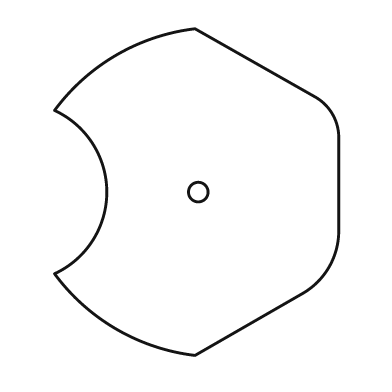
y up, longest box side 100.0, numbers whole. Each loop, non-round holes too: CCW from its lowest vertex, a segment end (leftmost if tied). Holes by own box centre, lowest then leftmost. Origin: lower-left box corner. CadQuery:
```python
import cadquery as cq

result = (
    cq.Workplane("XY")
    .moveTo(43.0, 0.0)
    .lineTo(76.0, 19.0)
    .threePointArc((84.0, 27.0), (87.0, 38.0))
    .lineTo(87.0, 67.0)
    .threePointArc((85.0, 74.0), (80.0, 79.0))
    .lineTo(43.0, 100.0)
    .threePointArc((19.0, 92.0), (0.0, 75.0))
    .threePointArc((16.0, 50.0), (0.0, 25.0))
    .threePointArc((19.0, 8.0), (43.0, 0.0))
    .close()
    .moveTo(44.0, 50.0)
    .circle(3.0)
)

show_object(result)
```